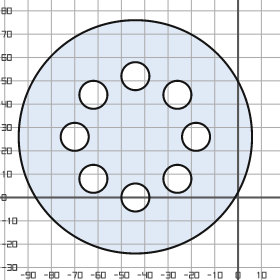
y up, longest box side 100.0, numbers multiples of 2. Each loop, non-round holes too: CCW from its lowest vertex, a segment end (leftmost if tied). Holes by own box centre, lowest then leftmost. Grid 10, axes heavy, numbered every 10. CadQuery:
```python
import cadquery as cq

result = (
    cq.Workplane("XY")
    .moveTo(-44.0, 26.0)
    .circle(50.0)
    .moveTo(-44.0, 0.0)
    .circle(6.0)
    .moveTo(-62.0, 8.0)
    .circle(6.0)
    .moveTo(-26.0, 8.0)
    .circle(6.0)
    .moveTo(-70.0, 26.0)
    .circle(6.0)
    .moveTo(-18.0, 26.0)
    .circle(6.0)
    .moveTo(-62.0, 44.0)
    .circle(6.0)
    .moveTo(-26.0, 44.0)
    .circle(6.0)
    .moveTo(-44.0, 52.0)
    .circle(6.0)
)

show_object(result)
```